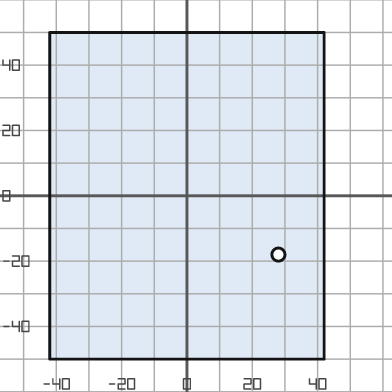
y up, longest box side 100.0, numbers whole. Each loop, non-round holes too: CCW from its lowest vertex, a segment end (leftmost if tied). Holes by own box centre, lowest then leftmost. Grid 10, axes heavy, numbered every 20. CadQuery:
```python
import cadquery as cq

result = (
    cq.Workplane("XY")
    .moveTo(-42.0, -50.0)
    .lineTo(42.0, -50.0)
    .lineTo(42.0, 50.0)
    .lineTo(-42.0, 50.0)
    .close()
    .moveTo(28.0, -18.0)
    .circle(2.0)
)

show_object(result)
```